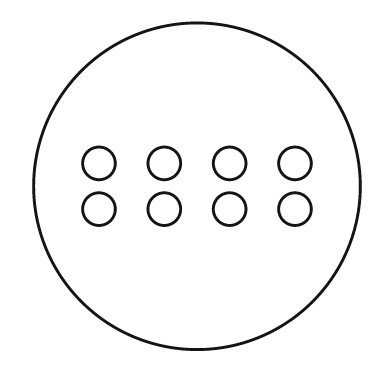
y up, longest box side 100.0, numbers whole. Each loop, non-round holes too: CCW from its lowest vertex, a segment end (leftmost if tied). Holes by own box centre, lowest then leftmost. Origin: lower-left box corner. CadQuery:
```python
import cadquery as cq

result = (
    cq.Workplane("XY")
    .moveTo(50.0, 50.0)
    .circle(50.0)
    .moveTo(20.0, 43.0)
    .circle(5.0)
    .moveTo(40.0, 43.0)
    .circle(5.0)
    .moveTo(60.0, 43.0)
    .circle(5.0)
    .moveTo(80.0, 43.0)
    .circle(5.0)
    .moveTo(20.0, 57.0)
    .circle(5.0)
    .moveTo(40.0, 57.0)
    .circle(5.0)
    .moveTo(60.0, 57.0)
    .circle(5.0)
    .moveTo(80.0, 57.0)
    .circle(5.0)
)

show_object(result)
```